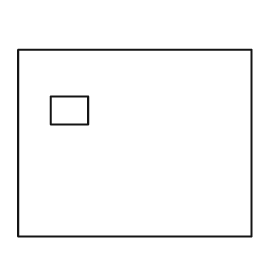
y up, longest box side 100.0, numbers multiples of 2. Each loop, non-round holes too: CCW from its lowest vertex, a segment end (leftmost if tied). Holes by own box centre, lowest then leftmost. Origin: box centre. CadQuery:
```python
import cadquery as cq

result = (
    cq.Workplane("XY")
    .moveTo(-50.0, -40.0)
    .lineTo(50.0, -40.0)
    .lineTo(50.0, 40.0)
    .lineTo(-50.0, 40.0)
    .close()
    .moveTo(-36.0, 8.0)
    .lineTo(-20.0, 8.0)
    .lineTo(-20.0, 20.0)
    .lineTo(-36.0, 20.0)
    .close()
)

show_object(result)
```